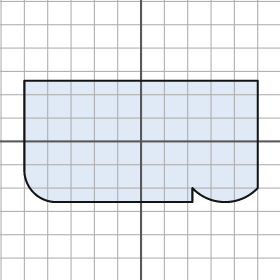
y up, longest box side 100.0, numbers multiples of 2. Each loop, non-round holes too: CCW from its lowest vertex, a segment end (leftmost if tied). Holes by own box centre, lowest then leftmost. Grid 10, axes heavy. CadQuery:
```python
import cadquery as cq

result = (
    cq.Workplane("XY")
    .moveTo(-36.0, -26.0)
    .lineTo(22.0, -26.0)
    .lineTo(22.0, -20.0)
    .threePointArc((36.0, -26.0), (50.0, -20.0))
    .lineTo(50.0, 26.0)
    .lineTo(-50.0, 26.0)
    .lineTo(-50.0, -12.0)
    .threePointArc((-46.0, -22.0), (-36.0, -26.0))
    .close()
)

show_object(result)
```